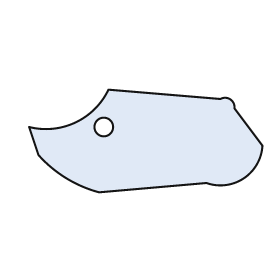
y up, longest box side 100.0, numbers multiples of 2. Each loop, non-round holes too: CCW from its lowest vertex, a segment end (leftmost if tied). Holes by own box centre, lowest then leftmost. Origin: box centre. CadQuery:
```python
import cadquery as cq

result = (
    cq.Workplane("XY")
    .moveTo(-20.0, -22.0)
    .lineTo(26.0, -18.0)
    .threePointArc((42.0, -16.0), (50.0, -2.0))
    .lineTo(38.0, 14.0)
    .threePointArc((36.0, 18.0), (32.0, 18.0))
    .lineTo(-16.0, 22.0)
    .threePointArc((-30.0, 8.0), (-50.0, 6.0))
    .lineTo(-46.0, -6.0)
    .threePointArc((-34.0, -16.0), (-20.0, -22.0))
    .close()
    .moveTo(-18.0, 6.0)
    .circle(4.0)
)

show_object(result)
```